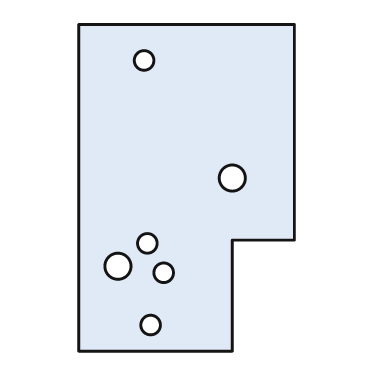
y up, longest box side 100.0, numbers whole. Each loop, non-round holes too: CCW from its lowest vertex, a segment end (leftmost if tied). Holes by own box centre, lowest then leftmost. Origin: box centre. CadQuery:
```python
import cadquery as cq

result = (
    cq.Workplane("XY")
    .moveTo(-33.0, -50.0)
    .lineTo(14.0, -50.0)
    .lineTo(14.0, -16.0)
    .lineTo(33.0, -16.0)
    .lineTo(33.0, 50.0)
    .lineTo(-33.0, 50.0)
    .close()
    .moveTo(-11.0, -42.0)
    .circle(3.0)
    .moveTo(-7.0, -26.0)
    .circle(3.0)
    .moveTo(-21.0, -24.0)
    .circle(4.0)
    .moveTo(-12.0, -17.0)
    .circle(3.0)
    .moveTo(14.0, 3.0)
    .circle(4.0)
    .moveTo(-13.0, 39.0)
    .circle(3.0)
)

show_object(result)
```